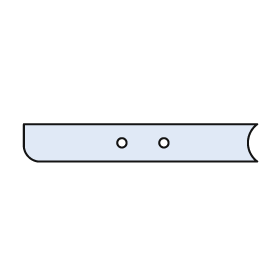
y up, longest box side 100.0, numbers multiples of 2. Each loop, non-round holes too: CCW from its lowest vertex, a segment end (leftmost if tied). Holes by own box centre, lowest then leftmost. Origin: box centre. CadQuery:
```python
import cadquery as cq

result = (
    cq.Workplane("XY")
    .moveTo(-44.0, -8.0)
    .lineTo(50.0, -8.0)
    .threePointArc((46.0, 0.0), (50.0, 8.0))
    .lineTo(-50.0, 8.0)
    .lineTo(-50.0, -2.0)
    .threePointArc((-48.0, -6.0), (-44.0, -8.0))
    .close()
    .moveTo(-8.0, 0.0)
    .circle(2.0)
    .moveTo(10.0, 0.0)
    .circle(2.0)
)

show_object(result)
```